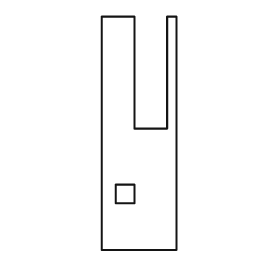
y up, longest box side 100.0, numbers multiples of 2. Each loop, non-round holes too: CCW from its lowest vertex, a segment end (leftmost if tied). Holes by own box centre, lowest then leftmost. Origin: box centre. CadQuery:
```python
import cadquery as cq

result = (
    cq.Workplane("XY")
    .moveTo(-16.0, -50.0)
    .lineTo(16.0, -50.0)
    .lineTo(16.0, 50.0)
    .lineTo(12.0, 50.0)
    .lineTo(12.0, 2.0)
    .lineTo(-2.0, 2.0)
    .lineTo(-2.0, 50.0)
    .lineTo(-16.0, 50.0)
    .close()
    .moveTo(-10.0, -30.0)
    .lineTo(-2.0, -30.0)
    .lineTo(-2.0, -22.0)
    .lineTo(-10.0, -22.0)
    .close()
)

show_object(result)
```